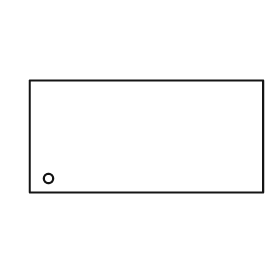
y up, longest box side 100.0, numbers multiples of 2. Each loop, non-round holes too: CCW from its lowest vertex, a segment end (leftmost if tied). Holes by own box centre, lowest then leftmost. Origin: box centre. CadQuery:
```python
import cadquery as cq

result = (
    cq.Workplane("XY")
    .moveTo(-50.0, -24.0)
    .lineTo(50.0, -24.0)
    .lineTo(50.0, 24.0)
    .lineTo(-50.0, 24.0)
    .close()
    .moveTo(-42.0, -18.0)
    .circle(2.0)
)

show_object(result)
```